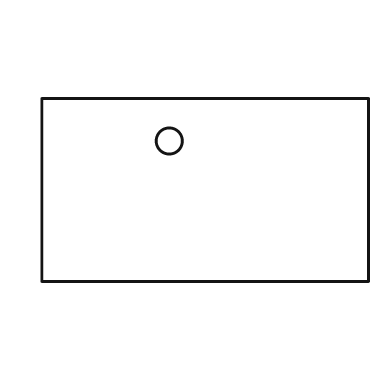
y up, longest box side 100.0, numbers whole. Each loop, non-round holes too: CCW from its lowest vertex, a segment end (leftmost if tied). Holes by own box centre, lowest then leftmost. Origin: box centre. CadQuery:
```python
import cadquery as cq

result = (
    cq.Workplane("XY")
    .moveTo(-50.0, -28.0)
    .lineTo(50.0, -28.0)
    .lineTo(50.0, 28.0)
    .lineTo(-50.0, 28.0)
    .close()
    .moveTo(-11.0, 15.0)
    .circle(4.0)
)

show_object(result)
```